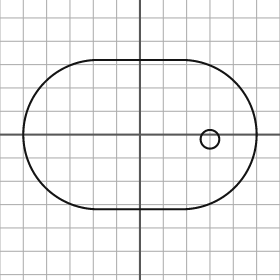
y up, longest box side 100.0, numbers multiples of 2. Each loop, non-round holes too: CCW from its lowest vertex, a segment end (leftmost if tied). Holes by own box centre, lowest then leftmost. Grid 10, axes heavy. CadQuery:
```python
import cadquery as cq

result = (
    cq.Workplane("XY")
    .moveTo(-18.0, -32.0)
    .lineTo(18.0, -32.0)
    .threePointArc((50.0, 0.0), (18.0, 32.0))
    .lineTo(-18.0, 32.0)
    .threePointArc((-50.0, 0.0), (-18.0, -32.0))
    .close()
    .moveTo(30.0, -2.0)
    .circle(4.0)
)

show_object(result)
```